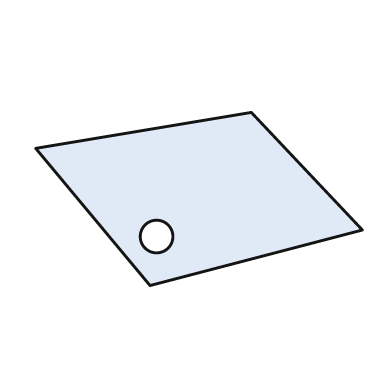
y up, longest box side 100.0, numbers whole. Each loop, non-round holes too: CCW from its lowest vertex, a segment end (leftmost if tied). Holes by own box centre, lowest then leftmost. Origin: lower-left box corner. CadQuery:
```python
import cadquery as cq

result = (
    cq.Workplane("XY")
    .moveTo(35.0, 0.0)
    .lineTo(100.0, 17.0)
    .lineTo(66.0, 53.0)
    .lineTo(0.0, 42.0)
    .close()
    .moveTo(37.0, 15.0)
    .circle(5.0)
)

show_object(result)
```